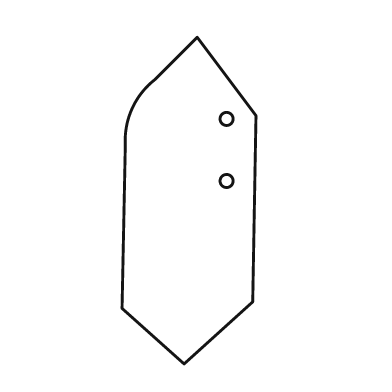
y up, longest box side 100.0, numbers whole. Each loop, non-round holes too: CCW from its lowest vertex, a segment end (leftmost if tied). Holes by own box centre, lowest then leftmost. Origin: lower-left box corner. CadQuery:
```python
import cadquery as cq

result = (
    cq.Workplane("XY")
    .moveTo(19.0, 0.0)
    .lineTo(40.0, 19.0)
    .lineTo(41.0, 76.0)
    .lineTo(23.0, 100.0)
    .lineTo(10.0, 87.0)
    .threePointArc((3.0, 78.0), (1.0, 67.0))
    .lineTo(0.0, 17.0)
    .close()
    .moveTo(32.0, 56.0)
    .circle(2.0)
    .moveTo(32.0, 75.0)
    .circle(2.0)
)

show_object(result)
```